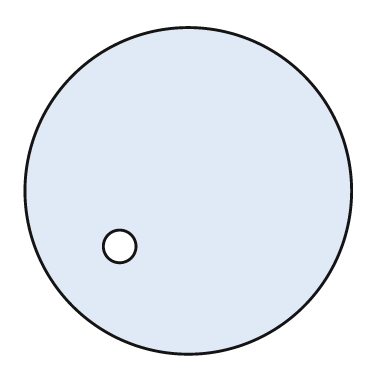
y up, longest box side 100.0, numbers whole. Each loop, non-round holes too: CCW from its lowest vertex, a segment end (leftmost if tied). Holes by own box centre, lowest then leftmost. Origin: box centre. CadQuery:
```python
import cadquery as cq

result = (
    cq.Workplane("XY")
    .moveTo(0.0, 0.0)
    .circle(50.0)
    .moveTo(-21.0, -17.0)
    .circle(5.0)
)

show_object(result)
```